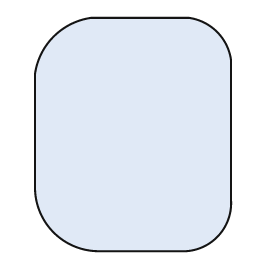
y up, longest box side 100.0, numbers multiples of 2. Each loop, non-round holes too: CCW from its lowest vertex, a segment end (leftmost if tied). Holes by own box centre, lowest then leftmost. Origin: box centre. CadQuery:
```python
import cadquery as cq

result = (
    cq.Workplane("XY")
    .moveTo(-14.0, -50.0)
    .lineTo(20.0, -50.0)
    .threePointArc((36.0, -44.0), (42.0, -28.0))
    .lineTo(42.0, 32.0)
    .threePointArc((36.0, 44.0), (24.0, 50.0))
    .lineTo(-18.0, 50.0)
    .threePointArc((-34.0, 42.0), (-42.0, 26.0))
    .lineTo(-42.0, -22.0)
    .threePointArc((-34.0, -42.0), (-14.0, -50.0))
    .close()
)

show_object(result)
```